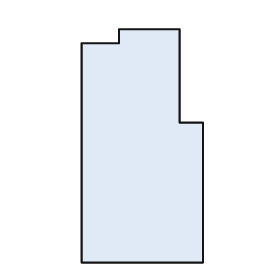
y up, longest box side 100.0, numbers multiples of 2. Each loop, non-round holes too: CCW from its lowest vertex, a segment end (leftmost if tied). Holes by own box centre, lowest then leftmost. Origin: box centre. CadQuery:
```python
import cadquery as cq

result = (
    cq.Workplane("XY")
    .moveTo(-26.0, -50.0)
    .lineTo(26.0, -50.0)
    .lineTo(26.0, 10.0)
    .lineTo(16.0, 10.0)
    .lineTo(16.0, 50.0)
    .lineTo(-10.0, 50.0)
    .lineTo(-10.0, 44.0)
    .lineTo(-26.0, 44.0)
    .close()
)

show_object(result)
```